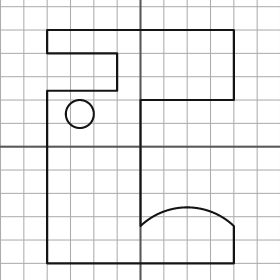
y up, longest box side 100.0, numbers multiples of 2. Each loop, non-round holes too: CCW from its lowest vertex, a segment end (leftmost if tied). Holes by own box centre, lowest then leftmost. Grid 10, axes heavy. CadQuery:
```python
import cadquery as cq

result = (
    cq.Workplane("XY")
    .moveTo(-40.0, -50.0)
    .lineTo(40.0, -50.0)
    .lineTo(40.0, -34.0)
    .threePointArc((20.0, -26.0), (0.0, -34.0))
    .lineTo(0.0, 20.0)
    .lineTo(40.0, 20.0)
    .lineTo(40.0, 50.0)
    .lineTo(-40.0, 50.0)
    .lineTo(-40.0, 40.0)
    .lineTo(-10.0, 40.0)
    .lineTo(-10.0, 24.0)
    .lineTo(-40.0, 24.0)
    .close()
    .moveTo(-26.0, 14.0)
    .circle(6.0)
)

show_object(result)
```